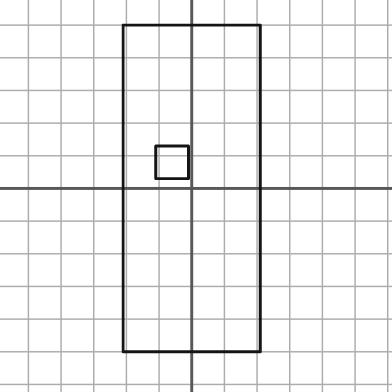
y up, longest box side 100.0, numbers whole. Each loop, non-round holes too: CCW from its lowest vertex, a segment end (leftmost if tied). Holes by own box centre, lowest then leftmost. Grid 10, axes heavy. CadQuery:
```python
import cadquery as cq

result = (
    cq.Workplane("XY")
    .moveTo(-21.0, -50.0)
    .lineTo(21.0, -50.0)
    .lineTo(21.0, 50.0)
    .lineTo(-21.0, 50.0)
    .close()
    .moveTo(-11.0, 3.0)
    .lineTo(-1.0, 3.0)
    .lineTo(-1.0, 13.0)
    .lineTo(-11.0, 13.0)
    .close()
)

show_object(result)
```